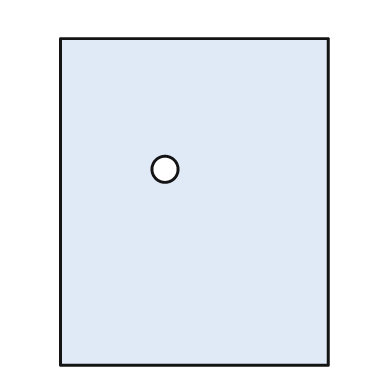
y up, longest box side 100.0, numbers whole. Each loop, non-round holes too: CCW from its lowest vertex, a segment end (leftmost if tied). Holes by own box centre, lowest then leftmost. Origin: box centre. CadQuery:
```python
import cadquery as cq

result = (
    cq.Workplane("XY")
    .moveTo(-41.0, -50.0)
    .lineTo(41.0, -50.0)
    .lineTo(41.0, 50.0)
    .lineTo(-41.0, 50.0)
    .close()
    .moveTo(-9.0, 10.0)
    .circle(4.0)
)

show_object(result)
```